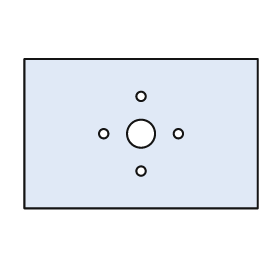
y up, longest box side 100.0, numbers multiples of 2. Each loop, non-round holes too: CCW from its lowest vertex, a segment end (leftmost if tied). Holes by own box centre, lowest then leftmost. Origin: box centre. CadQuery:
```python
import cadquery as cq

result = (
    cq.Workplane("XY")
    .moveTo(-50.0, -32.0)
    .lineTo(50.0, -32.0)
    .lineTo(50.0, 32.0)
    .lineTo(-50.0, 32.0)
    .close()
    .moveTo(0.0, -16.0)
    .circle(2.0)
    .moveTo(-16.0, 0.0)
    .circle(2.0)
    .moveTo(0.0, 0.0)
    .circle(6.0)
    .moveTo(16.0, 0.0)
    .circle(2.0)
    .moveTo(0.0, 16.0)
    .circle(2.0)
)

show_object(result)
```